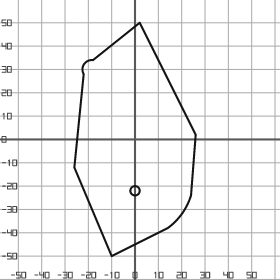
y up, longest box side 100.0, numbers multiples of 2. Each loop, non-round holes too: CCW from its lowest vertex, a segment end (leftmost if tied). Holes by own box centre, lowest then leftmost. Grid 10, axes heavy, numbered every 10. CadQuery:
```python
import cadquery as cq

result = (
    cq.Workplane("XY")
    .moveTo(-10.0, -50.0)
    .lineTo(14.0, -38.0)
    .threePointArc((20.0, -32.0), (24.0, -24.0))
    .lineTo(26.0, 2.0)
    .lineTo(2.0, 50.0)
    .lineTo(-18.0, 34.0)
    .threePointArc((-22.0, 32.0), (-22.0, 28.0))
    .lineTo(-26.0, -12.0)
    .close()
    .moveTo(0.0, -22.0)
    .circle(2.0)
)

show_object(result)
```